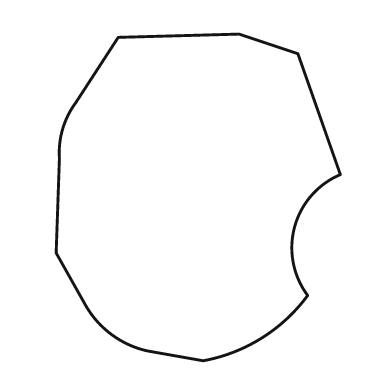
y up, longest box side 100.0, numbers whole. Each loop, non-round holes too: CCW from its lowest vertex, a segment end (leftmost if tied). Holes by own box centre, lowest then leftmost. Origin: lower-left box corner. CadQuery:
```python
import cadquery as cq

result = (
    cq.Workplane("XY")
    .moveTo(45.0, 0.0)
    .threePointArc((63.0, 7.0), (77.0, 20.0))
    .threePointArc((73.0, 41.0), (87.0, 57.0))
    .lineTo(74.0, 94.0)
    .lineTo(56.0, 100.0)
    .lineTo(19.0, 99.0)
    .lineTo(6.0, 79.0)
    .threePointArc((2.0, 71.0), (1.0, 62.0))
    .lineTo(0.0, 33.0)
    .lineTo(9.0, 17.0)
    .threePointArc((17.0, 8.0), (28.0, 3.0))
    .close()
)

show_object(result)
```